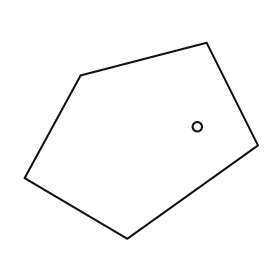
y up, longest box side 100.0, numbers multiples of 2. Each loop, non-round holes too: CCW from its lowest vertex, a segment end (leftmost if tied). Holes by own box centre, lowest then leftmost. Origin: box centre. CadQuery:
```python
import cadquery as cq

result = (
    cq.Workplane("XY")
    .moveTo(-6.0, -42.0)
    .lineTo(50.0, -2.0)
    .lineTo(28.0, 42.0)
    .lineTo(-26.0, 28.0)
    .lineTo(-50.0, -16.0)
    .close()
    .moveTo(24.0, 6.0)
    .circle(2.0)
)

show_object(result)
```